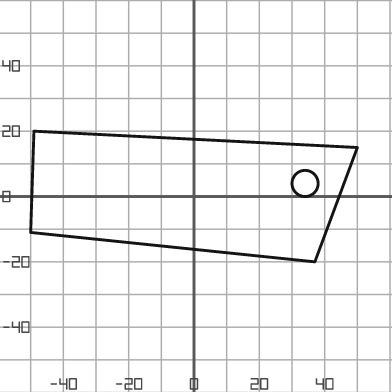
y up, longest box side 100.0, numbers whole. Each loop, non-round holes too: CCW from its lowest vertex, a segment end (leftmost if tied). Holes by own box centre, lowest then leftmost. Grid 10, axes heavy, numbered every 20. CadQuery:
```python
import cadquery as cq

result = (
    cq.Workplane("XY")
    .moveTo(37.0, -20.0)
    .lineTo(50.0, 15.0)
    .lineTo(-49.0, 20.0)
    .lineTo(-50.0, -11.0)
    .close()
    .moveTo(34.0, 4.0)
    .circle(4.0)
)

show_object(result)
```